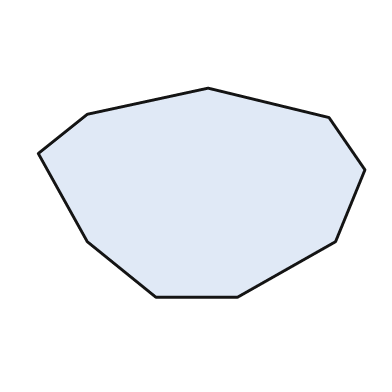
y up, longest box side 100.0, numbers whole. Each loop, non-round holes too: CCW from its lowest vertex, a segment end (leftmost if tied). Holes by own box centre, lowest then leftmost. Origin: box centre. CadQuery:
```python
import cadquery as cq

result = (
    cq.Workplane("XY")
    .moveTo(-14.0, -32.0)
    .lineTo(11.0, -32.0)
    .lineTo(41.0, -15.0)
    .lineTo(50.0, 7.0)
    .lineTo(39.0, 23.0)
    .lineTo(2.0, 32.0)
    .lineTo(-35.0, 24.0)
    .lineTo(-50.0, 12.0)
    .lineTo(-35.0, -15.0)
    .close()
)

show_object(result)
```